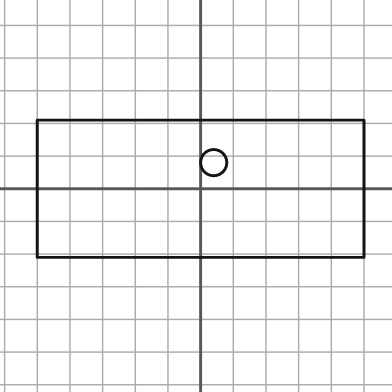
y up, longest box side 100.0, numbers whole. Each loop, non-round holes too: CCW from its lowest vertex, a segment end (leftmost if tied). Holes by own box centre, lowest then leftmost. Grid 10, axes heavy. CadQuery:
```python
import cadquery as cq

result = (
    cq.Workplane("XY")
    .moveTo(-50.0, -21.0)
    .lineTo(50.0, -21.0)
    .lineTo(50.0, 21.0)
    .lineTo(-50.0, 21.0)
    .close()
    .moveTo(4.0, 8.0)
    .circle(4.0)
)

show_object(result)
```